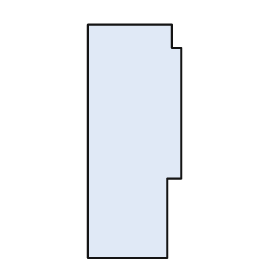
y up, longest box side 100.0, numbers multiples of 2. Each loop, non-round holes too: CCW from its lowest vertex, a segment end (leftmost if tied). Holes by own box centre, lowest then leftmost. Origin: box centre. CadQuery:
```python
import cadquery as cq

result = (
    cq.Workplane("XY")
    .moveTo(-20.0, -50.0)
    .lineTo(14.0, -50.0)
    .lineTo(14.0, -16.0)
    .lineTo(20.0, -16.0)
    .lineTo(20.0, 40.0)
    .lineTo(16.0, 40.0)
    .lineTo(16.0, 50.0)
    .lineTo(-20.0, 50.0)
    .close()
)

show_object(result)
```